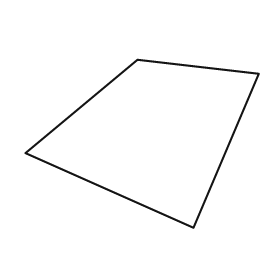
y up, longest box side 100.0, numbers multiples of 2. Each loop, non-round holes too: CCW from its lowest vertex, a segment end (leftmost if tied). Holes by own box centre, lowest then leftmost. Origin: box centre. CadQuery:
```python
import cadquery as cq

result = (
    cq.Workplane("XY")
    .moveTo(22.0, -36.0)
    .lineTo(50.0, 30.0)
    .lineTo(-2.0, 36.0)
    .lineTo(-50.0, -4.0)
    .close()
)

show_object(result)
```